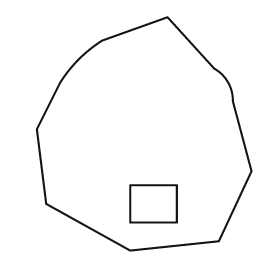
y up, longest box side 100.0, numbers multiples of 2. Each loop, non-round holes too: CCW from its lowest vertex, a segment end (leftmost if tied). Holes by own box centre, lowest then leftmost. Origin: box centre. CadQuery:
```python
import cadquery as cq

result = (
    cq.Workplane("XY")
    .moveTo(-6.0, -50.0)
    .lineTo(32.0, -46.0)
    .lineTo(46.0, -16.0)
    .lineTo(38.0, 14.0)
    .threePointArc((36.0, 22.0), (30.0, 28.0))
    .lineTo(10.0, 50.0)
    .lineTo(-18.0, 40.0)
    .threePointArc((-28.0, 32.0), (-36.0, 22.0))
    .lineTo(-46.0, 2.0)
    .lineTo(-42.0, -30.0)
    .close()
    .moveTo(-6.0, -38.0)
    .lineTo(14.0, -38.0)
    .lineTo(14.0, -22.0)
    .lineTo(-6.0, -22.0)
    .close()
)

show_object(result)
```